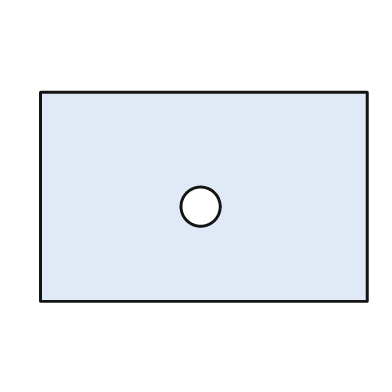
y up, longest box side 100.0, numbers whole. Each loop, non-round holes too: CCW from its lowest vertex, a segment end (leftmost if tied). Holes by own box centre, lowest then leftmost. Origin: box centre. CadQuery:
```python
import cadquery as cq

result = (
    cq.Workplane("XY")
    .moveTo(-50.0, -32.0)
    .lineTo(50.0, -32.0)
    .lineTo(50.0, 32.0)
    .lineTo(-50.0, 32.0)
    .close()
    .moveTo(-1.0, -3.0)
    .circle(6.0)
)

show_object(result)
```